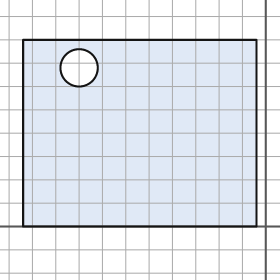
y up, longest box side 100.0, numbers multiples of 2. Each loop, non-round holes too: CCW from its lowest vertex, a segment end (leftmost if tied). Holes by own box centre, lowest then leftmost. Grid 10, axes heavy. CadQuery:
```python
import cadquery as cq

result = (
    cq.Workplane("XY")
    .moveTo(-104.0, 0.0)
    .lineTo(-4.0, 0.0)
    .lineTo(-4.0, 80.0)
    .lineTo(-104.0, 80.0)
    .close()
    .moveTo(-80.0, 68.0)
    .circle(8.0)
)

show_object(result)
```